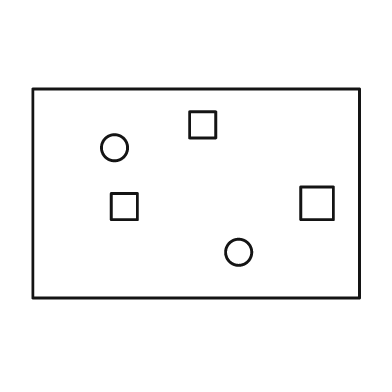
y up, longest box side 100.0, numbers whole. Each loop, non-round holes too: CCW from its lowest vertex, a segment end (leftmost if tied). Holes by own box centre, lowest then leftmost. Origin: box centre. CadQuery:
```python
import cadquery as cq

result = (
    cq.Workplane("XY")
    .moveTo(-50.0, -32.0)
    .lineTo(50.0, -32.0)
    .lineTo(50.0, 32.0)
    .lineTo(-50.0, 32.0)
    .close()
    .moveTo(13.0, -18.0)
    .circle(4.0)
    .moveTo(-26.0, -8.0)
    .lineTo(-18.0, -8.0)
    .lineTo(-18.0, 0.0)
    .lineTo(-26.0, 0.0)
    .close()
    .moveTo(32.0, -8.0)
    .lineTo(42.0, -8.0)
    .lineTo(42.0, 2.0)
    .lineTo(32.0, 2.0)
    .close()
    .moveTo(-25.0, 14.0)
    .circle(4.0)
    .moveTo(-2.0, 17.0)
    .lineTo(6.0, 17.0)
    .lineTo(6.0, 25.0)
    .lineTo(-2.0, 25.0)
    .close()
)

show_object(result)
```